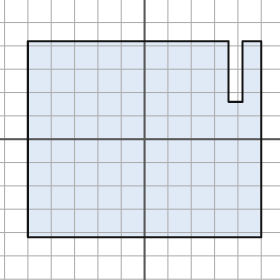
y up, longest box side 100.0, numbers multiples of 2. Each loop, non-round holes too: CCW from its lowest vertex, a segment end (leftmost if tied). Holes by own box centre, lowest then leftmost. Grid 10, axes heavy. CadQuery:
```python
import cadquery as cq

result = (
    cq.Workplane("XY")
    .moveTo(-50.0, -42.0)
    .lineTo(50.0, -42.0)
    .lineTo(50.0, 42.0)
    .lineTo(42.0, 42.0)
    .lineTo(42.0, 16.0)
    .lineTo(36.0, 16.0)
    .lineTo(36.0, 42.0)
    .lineTo(-50.0, 42.0)
    .close()
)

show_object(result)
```